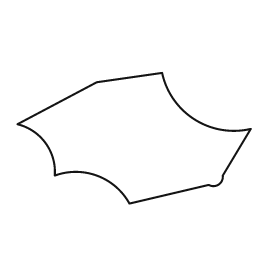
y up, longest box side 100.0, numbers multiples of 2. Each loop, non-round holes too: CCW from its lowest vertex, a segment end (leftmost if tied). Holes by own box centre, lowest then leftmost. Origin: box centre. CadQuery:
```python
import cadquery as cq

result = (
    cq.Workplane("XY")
    .moveTo(-2.0, -28.0)
    .lineTo(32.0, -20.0)
    .threePointArc((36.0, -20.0), (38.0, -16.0))
    .lineTo(50.0, 4.0)
    .threePointArc((26.0, 8.0), (12.0, 28.0))
    .lineTo(-16.0, 24.0)
    .lineTo(-50.0, 6.0)
    .threePointArc((-38.0, -2.0), (-34.0, -16.0))
    .threePointArc((-16.0, -16.0), (-2.0, -28.0))
    .close()
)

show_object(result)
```